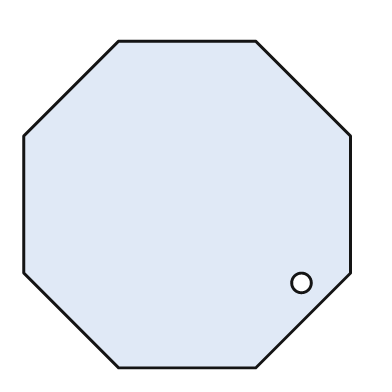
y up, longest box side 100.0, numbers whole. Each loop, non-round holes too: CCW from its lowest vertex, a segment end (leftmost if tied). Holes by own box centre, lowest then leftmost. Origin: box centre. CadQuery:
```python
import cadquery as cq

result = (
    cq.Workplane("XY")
    .moveTo(-21.0, -50.0)
    .lineTo(21.0, -50.0)
    .lineTo(50.0, -21.0)
    .lineTo(50.0, 21.0)
    .lineTo(21.0, 50.0)
    .lineTo(-21.0, 50.0)
    .lineTo(-50.0, 21.0)
    .lineTo(-50.0, -21.0)
    .close()
    .moveTo(35.0, -24.0)
    .circle(3.0)
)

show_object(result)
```